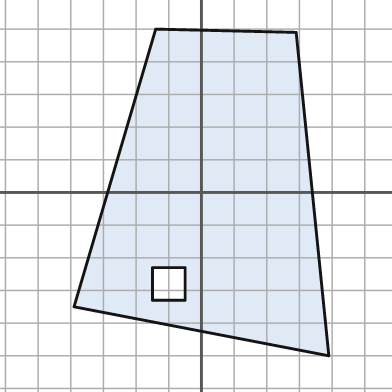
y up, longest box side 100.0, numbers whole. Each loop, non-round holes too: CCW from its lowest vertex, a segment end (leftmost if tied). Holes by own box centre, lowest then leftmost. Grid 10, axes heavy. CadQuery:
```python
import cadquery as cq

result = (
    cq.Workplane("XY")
    .moveTo(39.0, -50.0)
    .lineTo(29.0, 49.0)
    .lineTo(-14.0, 50.0)
    .lineTo(-39.0, -35.0)
    .close()
    .moveTo(-15.0, -33.0)
    .lineTo(-5.0, -33.0)
    .lineTo(-5.0, -23.0)
    .lineTo(-15.0, -23.0)
    .close()
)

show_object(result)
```